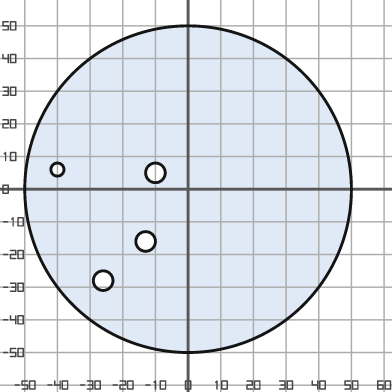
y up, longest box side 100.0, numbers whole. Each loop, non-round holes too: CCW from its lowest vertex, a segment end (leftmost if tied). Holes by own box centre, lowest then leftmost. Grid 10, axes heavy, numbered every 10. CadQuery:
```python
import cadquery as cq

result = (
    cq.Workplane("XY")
    .moveTo(0.0, 0.0)
    .circle(50.0)
    .moveTo(-26.0, -28.0)
    .circle(3.0)
    .moveTo(-13.0, -16.0)
    .circle(3.0)
    .moveTo(-10.0, 5.0)
    .circle(3.0)
    .moveTo(-40.0, 6.0)
    .circle(2.0)
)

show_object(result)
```